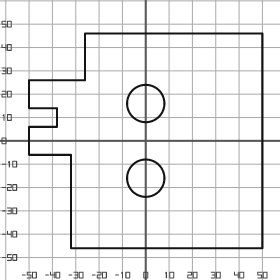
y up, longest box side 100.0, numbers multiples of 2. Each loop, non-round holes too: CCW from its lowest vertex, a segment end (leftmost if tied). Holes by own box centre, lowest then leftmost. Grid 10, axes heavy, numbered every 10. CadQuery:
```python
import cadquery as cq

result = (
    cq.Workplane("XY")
    .moveTo(-32.0, -46.0)
    .lineTo(50.0, -46.0)
    .lineTo(50.0, 46.0)
    .lineTo(-26.0, 46.0)
    .lineTo(-26.0, 26.0)
    .lineTo(-50.0, 26.0)
    .lineTo(-50.0, 14.0)
    .lineTo(-38.0, 14.0)
    .lineTo(-38.0, 6.0)
    .lineTo(-50.0, 6.0)
    .lineTo(-50.0, -6.0)
    .lineTo(-32.0, -6.0)
    .close()
    .moveTo(0.0, -16.0)
    .circle(8.0)
    .moveTo(0.0, 16.0)
    .circle(8.0)
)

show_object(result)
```